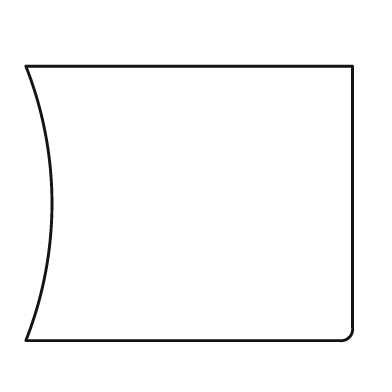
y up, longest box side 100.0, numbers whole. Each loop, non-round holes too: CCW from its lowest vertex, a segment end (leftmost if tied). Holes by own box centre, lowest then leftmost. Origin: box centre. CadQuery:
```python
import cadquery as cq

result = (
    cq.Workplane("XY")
    .moveTo(-50.0, -42.0)
    .lineTo(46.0, -42.0)
    .threePointArc((49.0, -41.0), (50.0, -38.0))
    .lineTo(50.0, 42.0)
    .lineTo(-50.0, 42.0)
    .threePointArc((-42.0, 0.0), (-50.0, -42.0))
    .close()
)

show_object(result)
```